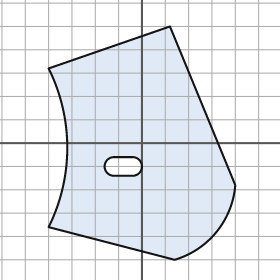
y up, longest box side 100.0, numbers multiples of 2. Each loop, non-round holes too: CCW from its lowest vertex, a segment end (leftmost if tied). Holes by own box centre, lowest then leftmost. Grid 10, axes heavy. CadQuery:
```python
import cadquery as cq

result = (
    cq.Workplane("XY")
    .moveTo(14.0, -50.0)
    .threePointArc((32.0, -38.0), (40.0, -18.0))
    .lineTo(12.0, 50.0)
    .lineTo(-40.0, 32.0)
    .threePointArc((-32.0, -2.0), (-40.0, -36.0))
    .close()
    .moveTo(-12.0, -14.0)
    .lineTo(-4.0, -14.0)
    .threePointArc((0.0, -10.0), (-4.0, -6.0))
    .lineTo(-12.0, -6.0)
    .threePointArc((-16.0, -10.0), (-12.0, -14.0))
    .close()
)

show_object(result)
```